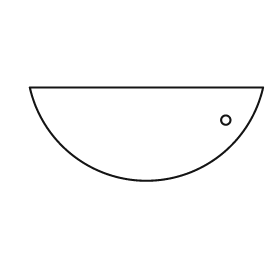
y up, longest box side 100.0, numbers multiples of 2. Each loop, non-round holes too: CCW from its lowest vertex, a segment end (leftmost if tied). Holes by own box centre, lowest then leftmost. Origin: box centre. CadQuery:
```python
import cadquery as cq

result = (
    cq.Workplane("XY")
    .moveTo(-50.0, 20.0)
    .threePointArc((0.0, -20.0), (50.0, 20.0))
    .close()
    .moveTo(34.0, 6.0)
    .circle(2.0)
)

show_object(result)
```